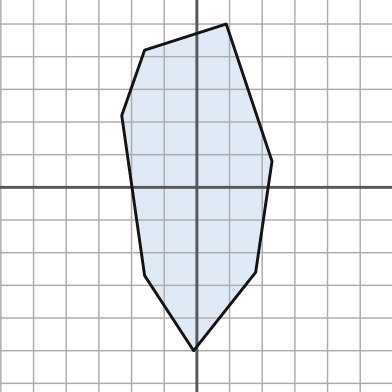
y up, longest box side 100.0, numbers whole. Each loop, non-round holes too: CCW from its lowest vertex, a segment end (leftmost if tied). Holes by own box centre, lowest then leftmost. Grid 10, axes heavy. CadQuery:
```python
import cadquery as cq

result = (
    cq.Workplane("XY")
    .moveTo(-1.0, -50.0)
    .lineTo(18.0, -26.0)
    .lineTo(23.0, 8.0)
    .lineTo(9.0, 50.0)
    .lineTo(-16.0, 42.0)
    .lineTo(-23.0, 22.0)
    .lineTo(-16.0, -27.0)
    .close()
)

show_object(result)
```